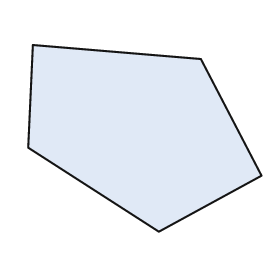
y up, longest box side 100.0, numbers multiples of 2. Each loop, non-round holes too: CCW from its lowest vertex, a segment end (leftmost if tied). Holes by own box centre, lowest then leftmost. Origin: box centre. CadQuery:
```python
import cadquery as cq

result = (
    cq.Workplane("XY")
    .moveTo(6.0, -40.0)
    .lineTo(50.0, -16.0)
    .lineTo(24.0, 34.0)
    .lineTo(-48.0, 40.0)
    .lineTo(-50.0, -4.0)
    .close()
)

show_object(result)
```